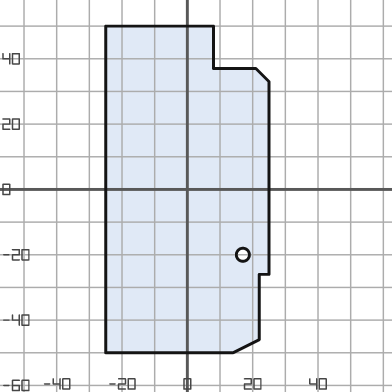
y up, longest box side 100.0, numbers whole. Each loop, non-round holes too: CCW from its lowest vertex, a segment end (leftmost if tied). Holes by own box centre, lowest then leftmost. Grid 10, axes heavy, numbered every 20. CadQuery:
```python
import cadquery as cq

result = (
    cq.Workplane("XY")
    .moveTo(-25.0, -50.0)
    .lineTo(14.0, -50.0)
    .lineTo(22.0, -46.0)
    .lineTo(22.0, -26.0)
    .lineTo(25.0, -26.0)
    .lineTo(25.0, 33.0)
    .lineTo(21.0, 37.0)
    .lineTo(8.0, 37.0)
    .lineTo(8.0, 50.0)
    .lineTo(-25.0, 50.0)
    .close()
    .moveTo(17.0, -20.0)
    .circle(2.0)
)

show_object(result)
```